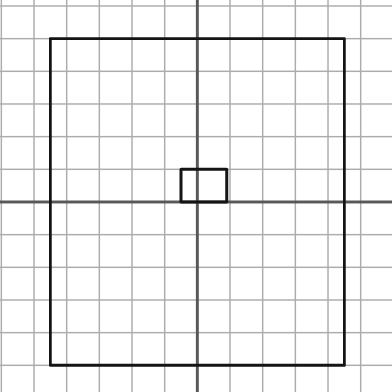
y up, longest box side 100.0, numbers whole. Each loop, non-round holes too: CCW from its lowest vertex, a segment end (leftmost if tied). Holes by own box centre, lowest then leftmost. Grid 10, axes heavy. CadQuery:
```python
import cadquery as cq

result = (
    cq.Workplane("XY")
    .moveTo(-45.0, -50.0)
    .lineTo(45.0, -50.0)
    .lineTo(45.0, 50.0)
    .lineTo(-45.0, 50.0)
    .close()
    .moveTo(-5.0, 0.0)
    .lineTo(9.0, 0.0)
    .lineTo(9.0, 10.0)
    .lineTo(-5.0, 10.0)
    .close()
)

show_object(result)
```